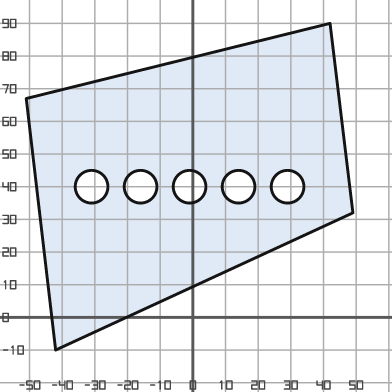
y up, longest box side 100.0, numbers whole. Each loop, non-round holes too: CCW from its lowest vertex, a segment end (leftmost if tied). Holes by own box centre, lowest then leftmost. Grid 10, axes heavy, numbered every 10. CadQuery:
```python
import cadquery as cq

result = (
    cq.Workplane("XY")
    .moveTo(-42.0, -10.0)
    .lineTo(49.0, 32.0)
    .lineTo(42.0, 90.0)
    .lineTo(-51.0, 67.0)
    .close()
    .moveTo(-31.0, 40.0)
    .circle(5.0)
    .moveTo(-16.0, 40.0)
    .circle(5.0)
    .moveTo(-1.0, 40.0)
    .circle(5.0)
    .moveTo(14.0, 40.0)
    .circle(5.0)
    .moveTo(29.0, 40.0)
    .circle(5.0)
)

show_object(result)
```